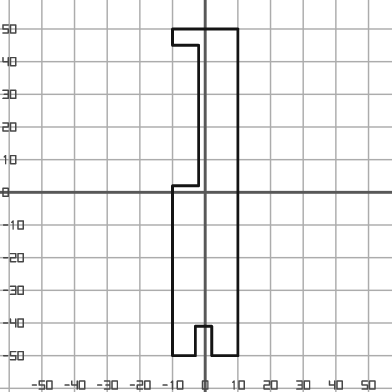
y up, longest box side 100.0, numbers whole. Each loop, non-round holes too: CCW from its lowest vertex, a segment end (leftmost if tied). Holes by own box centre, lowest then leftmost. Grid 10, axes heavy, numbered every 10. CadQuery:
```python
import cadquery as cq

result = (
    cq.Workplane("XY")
    .moveTo(-10.0, -50.0)
    .lineTo(-3.0, -50.0)
    .lineTo(-3.0, -41.0)
    .lineTo(2.0, -41.0)
    .lineTo(2.0, -50.0)
    .lineTo(10.0, -50.0)
    .lineTo(10.0, 50.0)
    .lineTo(-10.0, 50.0)
    .lineTo(-10.0, 45.0)
    .lineTo(-2.0, 45.0)
    .lineTo(-2.0, 2.0)
    .lineTo(-10.0, 2.0)
    .close()
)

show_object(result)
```